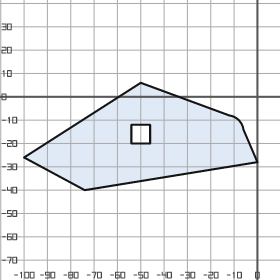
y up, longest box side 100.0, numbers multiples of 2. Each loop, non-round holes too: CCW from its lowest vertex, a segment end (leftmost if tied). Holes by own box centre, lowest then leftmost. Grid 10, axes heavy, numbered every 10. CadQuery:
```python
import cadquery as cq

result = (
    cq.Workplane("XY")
    .moveTo(-74.0, -40.0)
    .lineTo(0.0, -28.0)
    .lineTo(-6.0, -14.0)
    .threePointArc((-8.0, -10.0), (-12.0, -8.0))
    .lineTo(-50.0, 6.0)
    .lineTo(-100.0, -26.0)
    .close()
    .moveTo(-54.0, -20.0)
    .lineTo(-46.0, -20.0)
    .lineTo(-46.0, -12.0)
    .lineTo(-54.0, -12.0)
    .close()
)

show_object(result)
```